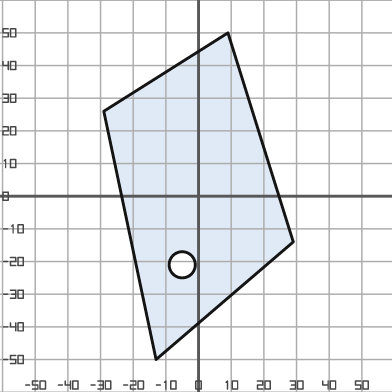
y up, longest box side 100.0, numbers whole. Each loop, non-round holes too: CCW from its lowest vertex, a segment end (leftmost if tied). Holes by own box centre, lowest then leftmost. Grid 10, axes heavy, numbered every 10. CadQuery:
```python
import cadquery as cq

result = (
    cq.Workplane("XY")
    .moveTo(-13.0, -50.0)
    .lineTo(29.0, -14.0)
    .lineTo(9.0, 50.0)
    .lineTo(-29.0, 26.0)
    .close()
    .moveTo(-5.0, -21.0)
    .circle(4.0)
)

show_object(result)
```